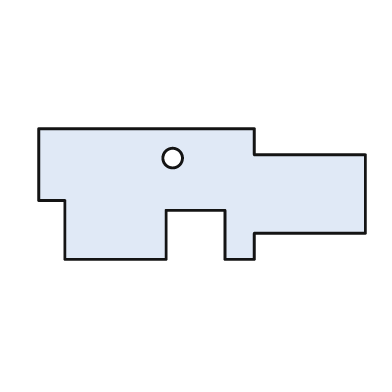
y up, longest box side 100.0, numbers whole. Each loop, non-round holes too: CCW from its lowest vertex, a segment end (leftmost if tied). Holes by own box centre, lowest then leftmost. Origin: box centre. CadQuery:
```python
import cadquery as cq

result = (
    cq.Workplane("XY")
    .moveTo(-42.0, -20.0)
    .lineTo(-11.0, -20.0)
    .lineTo(-11.0, -5.0)
    .lineTo(7.0, -5.0)
    .lineTo(7.0, -20.0)
    .lineTo(16.0, -20.0)
    .lineTo(16.0, -12.0)
    .lineTo(50.0, -12.0)
    .lineTo(50.0, 12.0)
    .lineTo(16.0, 12.0)
    .lineTo(16.0, 20.0)
    .lineTo(-50.0, 20.0)
    .lineTo(-50.0, -2.0)
    .lineTo(-42.0, -2.0)
    .close()
    .moveTo(-9.0, 11.0)
    .circle(3.0)
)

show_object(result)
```